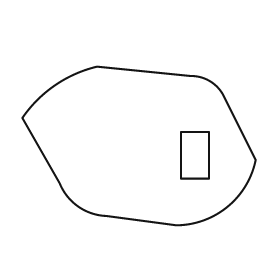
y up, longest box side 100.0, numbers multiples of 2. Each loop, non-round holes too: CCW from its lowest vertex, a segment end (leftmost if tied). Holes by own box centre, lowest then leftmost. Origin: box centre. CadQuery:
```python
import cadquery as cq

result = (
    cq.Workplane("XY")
    .moveTo(16.0, -34.0)
    .threePointArc((38.0, -26.0), (50.0, -6.0))
    .lineTo(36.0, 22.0)
    .threePointArc((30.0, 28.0), (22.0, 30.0))
    .lineTo(-18.0, 34.0)
    .threePointArc((-36.0, 26.0), (-50.0, 12.0))
    .lineTo(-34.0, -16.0)
    .threePointArc((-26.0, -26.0), (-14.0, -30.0))
    .close()
    .moveTo(18.0, -14.0)
    .lineTo(30.0, -14.0)
    .lineTo(30.0, 6.0)
    .lineTo(18.0, 6.0)
    .close()
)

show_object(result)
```